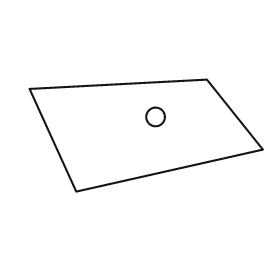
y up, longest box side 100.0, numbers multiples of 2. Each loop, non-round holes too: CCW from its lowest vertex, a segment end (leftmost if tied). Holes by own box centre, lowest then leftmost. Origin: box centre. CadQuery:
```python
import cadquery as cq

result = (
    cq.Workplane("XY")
    .moveTo(-30.0, -24.0)
    .lineTo(50.0, -6.0)
    .lineTo(26.0, 24.0)
    .lineTo(-50.0, 20.0)
    .close()
    .moveTo(4.0, 8.0)
    .circle(4.0)
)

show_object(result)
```